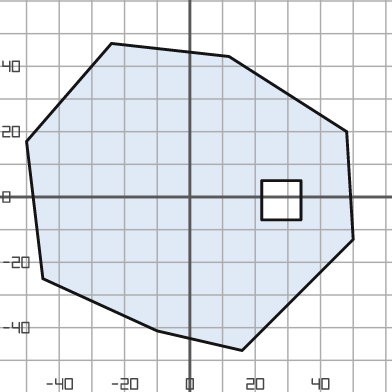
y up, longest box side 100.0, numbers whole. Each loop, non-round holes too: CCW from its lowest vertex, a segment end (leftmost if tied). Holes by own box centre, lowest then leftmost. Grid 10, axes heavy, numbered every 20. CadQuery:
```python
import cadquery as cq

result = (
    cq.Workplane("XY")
    .moveTo(16.0, -47.0)
    .lineTo(50.0, -13.0)
    .lineTo(48.0, 20.0)
    .lineTo(12.0, 43.0)
    .lineTo(-24.0, 47.0)
    .lineTo(-50.0, 17.0)
    .lineTo(-45.0, -25.0)
    .lineTo(-10.0, -41.0)
    .close()
    .moveTo(22.0, -7.0)
    .lineTo(34.0, -7.0)
    .lineTo(34.0, 5.0)
    .lineTo(22.0, 5.0)
    .close()
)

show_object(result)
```